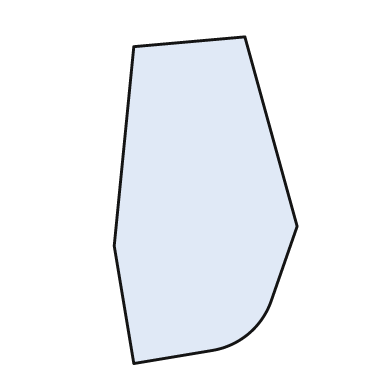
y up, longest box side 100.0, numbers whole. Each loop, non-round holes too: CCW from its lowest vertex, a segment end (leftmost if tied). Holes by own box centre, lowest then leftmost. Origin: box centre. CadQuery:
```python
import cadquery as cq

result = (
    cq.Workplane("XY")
    .moveTo(-22.0, -50.0)
    .lineTo(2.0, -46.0)
    .threePointArc((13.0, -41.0), (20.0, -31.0))
    .lineTo(28.0, -8.0)
    .lineTo(12.0, 50.0)
    .lineTo(-22.0, 47.0)
    .lineTo(-28.0, -14.0)
    .close()
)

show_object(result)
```